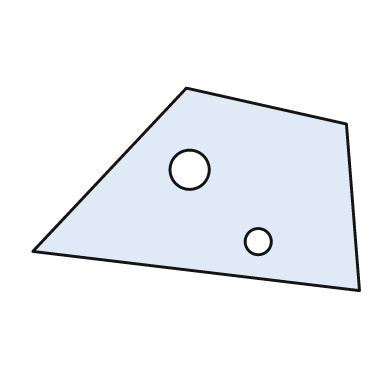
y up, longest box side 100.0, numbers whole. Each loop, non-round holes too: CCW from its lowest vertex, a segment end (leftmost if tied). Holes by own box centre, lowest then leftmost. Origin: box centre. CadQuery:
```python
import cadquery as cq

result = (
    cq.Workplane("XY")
    .moveTo(50.0, -31.0)
    .lineTo(46.0, 20.0)
    .lineTo(-3.0, 31.0)
    .lineTo(-50.0, -19.0)
    .close()
    .moveTo(19.0, -16.0)
    .circle(4.0)
    .moveTo(-2.0, 6.0)
    .circle(6.0)
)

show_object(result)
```